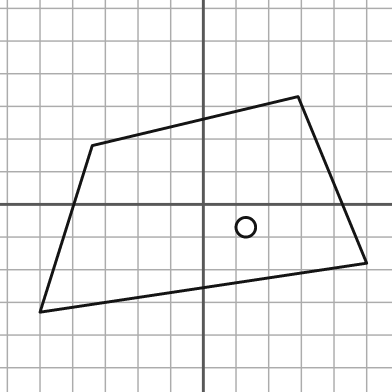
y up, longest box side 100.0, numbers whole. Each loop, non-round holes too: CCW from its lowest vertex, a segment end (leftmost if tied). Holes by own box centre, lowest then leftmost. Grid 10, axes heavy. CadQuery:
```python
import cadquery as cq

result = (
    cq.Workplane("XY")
    .moveTo(-50.0, -33.0)
    .lineTo(50.0, -18.0)
    .lineTo(29.0, 33.0)
    .lineTo(-34.0, 18.0)
    .close()
    .moveTo(13.0, -7.0)
    .circle(3.0)
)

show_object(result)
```